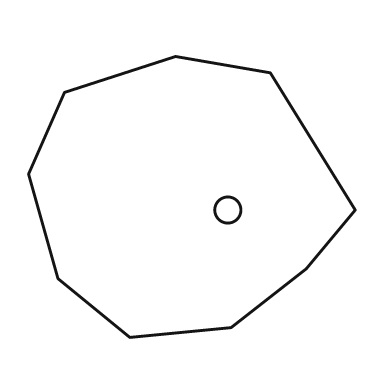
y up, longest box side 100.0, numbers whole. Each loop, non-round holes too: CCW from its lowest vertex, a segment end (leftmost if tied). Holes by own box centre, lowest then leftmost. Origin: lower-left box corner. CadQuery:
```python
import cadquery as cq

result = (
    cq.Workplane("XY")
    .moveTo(31.0, 0.0)
    .lineTo(62.0, 3.0)
    .lineTo(85.0, 21.0)
    .lineTo(100.0, 39.0)
    .lineTo(74.0, 81.0)
    .lineTo(45.0, 86.0)
    .lineTo(11.0, 75.0)
    .lineTo(0.0, 50.0)
    .lineTo(9.0, 18.0)
    .close()
    .moveTo(61.0, 39.0)
    .circle(4.0)
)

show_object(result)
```